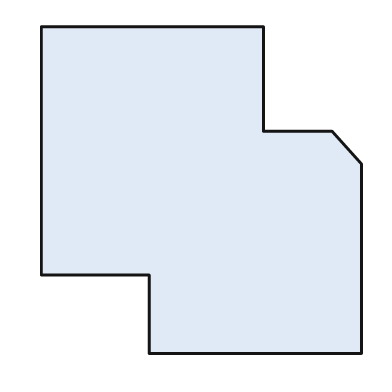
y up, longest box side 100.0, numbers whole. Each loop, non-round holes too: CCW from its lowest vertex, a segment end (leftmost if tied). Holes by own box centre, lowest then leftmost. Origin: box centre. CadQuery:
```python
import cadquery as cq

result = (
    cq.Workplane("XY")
    .moveTo(-16.0, -50.0)
    .lineTo(49.0, -50.0)
    .lineTo(49.0, 8.0)
    .lineTo(40.0, 18.0)
    .lineTo(19.0, 18.0)
    .lineTo(19.0, 50.0)
    .lineTo(-49.0, 50.0)
    .lineTo(-49.0, -26.0)
    .lineTo(-16.0, -26.0)
    .close()
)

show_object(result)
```